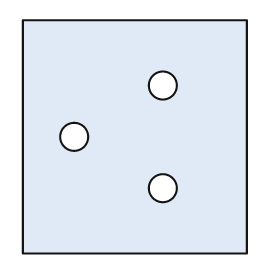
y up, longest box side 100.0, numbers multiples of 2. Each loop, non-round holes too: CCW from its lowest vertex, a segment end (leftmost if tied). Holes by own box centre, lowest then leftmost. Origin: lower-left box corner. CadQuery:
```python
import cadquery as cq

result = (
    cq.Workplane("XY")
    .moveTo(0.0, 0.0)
    .lineTo(96.0, 0.0)
    .lineTo(96.0, 100.0)
    .lineTo(0.0, 100.0)
    .close()
    .moveTo(60.0, 28.0)
    .circle(6.0)
    .moveTo(22.0, 50.0)
    .circle(6.0)
    .moveTo(60.0, 72.0)
    .circle(6.0)
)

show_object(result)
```